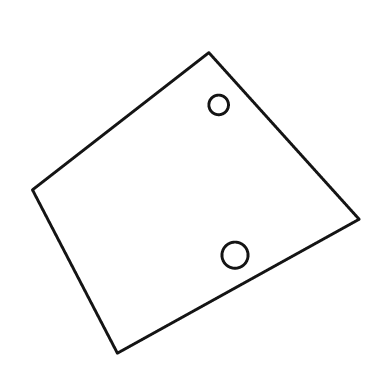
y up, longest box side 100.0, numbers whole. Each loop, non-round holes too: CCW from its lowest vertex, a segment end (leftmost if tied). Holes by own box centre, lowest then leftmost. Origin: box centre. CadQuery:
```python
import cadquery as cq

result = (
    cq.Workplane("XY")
    .moveTo(-24.0, -46.0)
    .lineTo(50.0, -5.0)
    .lineTo(4.0, 46.0)
    .lineTo(-50.0, 4.0)
    .close()
    .moveTo(12.0, -16.0)
    .circle(4.0)
    .moveTo(7.0, 30.0)
    .circle(3.0)
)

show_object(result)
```